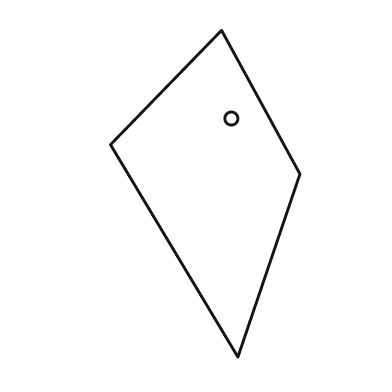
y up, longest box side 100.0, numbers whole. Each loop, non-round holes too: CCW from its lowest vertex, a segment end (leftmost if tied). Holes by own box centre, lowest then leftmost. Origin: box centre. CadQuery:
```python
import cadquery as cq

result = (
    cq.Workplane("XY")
    .moveTo(10.0, -50.0)
    .lineTo(29.0, 6.0)
    .lineTo(5.0, 50.0)
    .lineTo(-29.0, 15.0)
    .close()
    .moveTo(8.0, 23.0)
    .circle(2.0)
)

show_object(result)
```